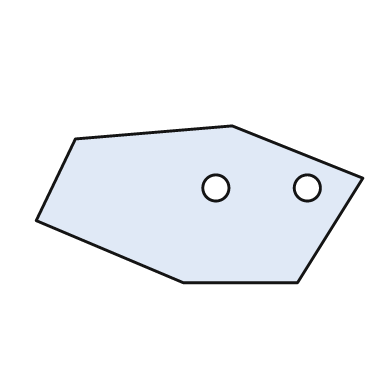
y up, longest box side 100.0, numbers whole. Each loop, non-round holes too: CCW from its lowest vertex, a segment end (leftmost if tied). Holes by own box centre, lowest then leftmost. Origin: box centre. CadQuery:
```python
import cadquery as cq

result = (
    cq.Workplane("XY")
    .moveTo(-5.0, -24.0)
    .lineTo(30.0, -24.0)
    .lineTo(50.0, 8.0)
    .lineTo(10.0, 24.0)
    .lineTo(-38.0, 20.0)
    .lineTo(-50.0, -5.0)
    .close()
    .moveTo(5.0, 5.0)
    .circle(4.0)
    .moveTo(33.0, 5.0)
    .circle(4.0)
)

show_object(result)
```